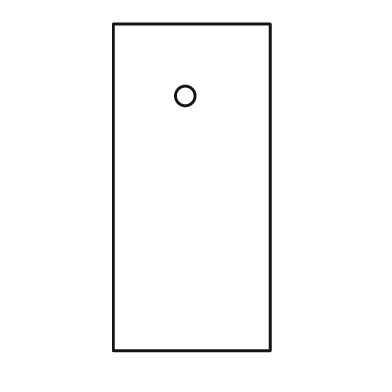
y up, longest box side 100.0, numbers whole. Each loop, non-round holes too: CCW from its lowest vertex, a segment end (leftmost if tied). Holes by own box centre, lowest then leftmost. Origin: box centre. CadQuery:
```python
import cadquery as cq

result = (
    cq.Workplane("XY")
    .moveTo(-24.0, -50.0)
    .lineTo(24.0, -50.0)
    .lineTo(24.0, 50.0)
    .lineTo(-24.0, 50.0)
    .close()
    .moveTo(-2.0, 28.0)
    .circle(3.0)
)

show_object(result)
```